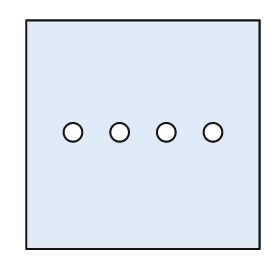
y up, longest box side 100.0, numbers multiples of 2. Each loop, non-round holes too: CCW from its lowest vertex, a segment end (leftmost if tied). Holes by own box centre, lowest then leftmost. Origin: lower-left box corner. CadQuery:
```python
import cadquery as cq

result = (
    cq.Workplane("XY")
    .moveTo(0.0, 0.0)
    .lineTo(100.0, 0.0)
    .lineTo(100.0, 98.0)
    .lineTo(0.0, 98.0)
    .close()
    .moveTo(20.0, 50.0)
    .circle(4.0)
    .moveTo(40.0, 50.0)
    .circle(4.0)
    .moveTo(60.0, 50.0)
    .circle(4.0)
    .moveTo(80.0, 50.0)
    .circle(4.0)
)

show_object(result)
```